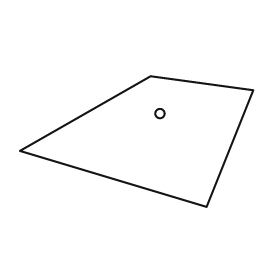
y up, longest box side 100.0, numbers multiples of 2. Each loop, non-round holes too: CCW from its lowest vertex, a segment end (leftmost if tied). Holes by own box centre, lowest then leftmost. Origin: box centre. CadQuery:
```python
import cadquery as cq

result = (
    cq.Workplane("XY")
    .moveTo(30.0, -28.0)
    .lineTo(50.0, 22.0)
    .lineTo(6.0, 28.0)
    .lineTo(-50.0, -4.0)
    .close()
    .moveTo(10.0, 12.0)
    .circle(2.0)
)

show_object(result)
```